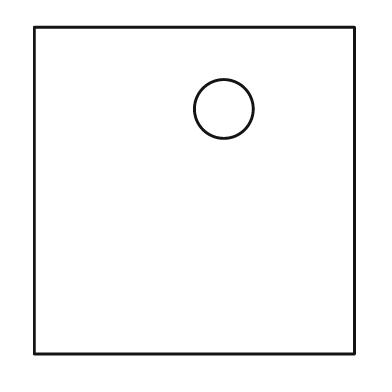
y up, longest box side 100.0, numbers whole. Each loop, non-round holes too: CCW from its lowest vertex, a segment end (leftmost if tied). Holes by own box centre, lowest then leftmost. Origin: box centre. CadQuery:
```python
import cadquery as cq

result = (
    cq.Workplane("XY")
    .moveTo(-49.0, -50.0)
    .lineTo(49.0, -50.0)
    .lineTo(49.0, 50.0)
    .lineTo(-49.0, 50.0)
    .close()
    .moveTo(9.0, 25.0)
    .circle(9.0)
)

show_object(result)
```